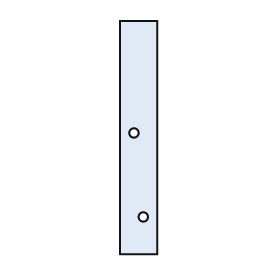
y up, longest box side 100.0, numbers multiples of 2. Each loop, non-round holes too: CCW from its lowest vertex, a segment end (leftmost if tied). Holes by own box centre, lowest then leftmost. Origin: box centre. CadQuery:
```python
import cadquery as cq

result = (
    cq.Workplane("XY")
    .moveTo(-8.0, -50.0)
    .lineTo(8.0, -50.0)
    .lineTo(8.0, 50.0)
    .lineTo(-8.0, 50.0)
    .close()
    .moveTo(2.0, -34.0)
    .circle(2.0)
    .moveTo(-2.0, 2.0)
    .circle(2.0)
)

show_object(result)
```